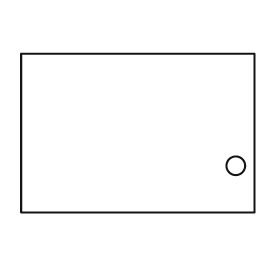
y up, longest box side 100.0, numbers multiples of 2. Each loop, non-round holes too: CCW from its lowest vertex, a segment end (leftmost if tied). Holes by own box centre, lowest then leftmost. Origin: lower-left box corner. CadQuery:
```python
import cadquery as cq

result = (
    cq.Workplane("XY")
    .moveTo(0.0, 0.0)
    .lineTo(100.0, 0.0)
    .lineTo(100.0, 68.0)
    .lineTo(0.0, 68.0)
    .close()
    .moveTo(92.0, 20.0)
    .circle(4.0)
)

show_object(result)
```